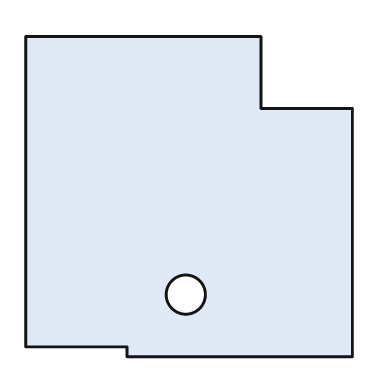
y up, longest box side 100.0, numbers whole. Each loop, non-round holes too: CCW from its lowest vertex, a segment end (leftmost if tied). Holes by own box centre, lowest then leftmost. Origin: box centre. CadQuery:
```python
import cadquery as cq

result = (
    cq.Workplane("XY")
    .moveTo(-19.0, -49.0)
    .lineTo(50.0, -49.0)
    .lineTo(50.0, 27.0)
    .lineTo(22.0, 27.0)
    .lineTo(22.0, 49.0)
    .lineTo(-50.0, 49.0)
    .lineTo(-50.0, -46.0)
    .lineTo(-19.0, -46.0)
    .close()
    .moveTo(-1.0, -30.0)
    .circle(6.0)
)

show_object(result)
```